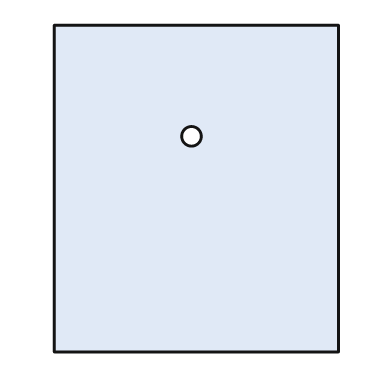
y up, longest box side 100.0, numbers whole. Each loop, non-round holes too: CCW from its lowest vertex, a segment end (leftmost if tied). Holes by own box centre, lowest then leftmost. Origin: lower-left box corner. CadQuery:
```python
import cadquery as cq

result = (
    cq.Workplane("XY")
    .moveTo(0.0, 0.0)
    .lineTo(87.0, 0.0)
    .lineTo(87.0, 100.0)
    .lineTo(0.0, 100.0)
    .close()
    .moveTo(42.0, 66.0)
    .circle(3.0)
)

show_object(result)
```